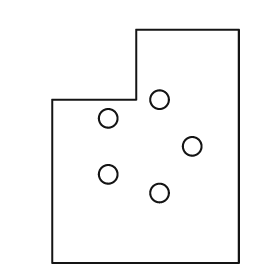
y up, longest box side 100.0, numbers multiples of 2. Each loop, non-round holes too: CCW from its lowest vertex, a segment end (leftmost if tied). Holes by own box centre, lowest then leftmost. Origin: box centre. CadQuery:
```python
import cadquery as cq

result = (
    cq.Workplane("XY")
    .moveTo(-40.0, -50.0)
    .lineTo(40.0, -50.0)
    .lineTo(40.0, 50.0)
    .lineTo(-4.0, 50.0)
    .lineTo(-4.0, 20.0)
    .lineTo(-40.0, 20.0)
    .close()
    .moveTo(6.0, -20.0)
    .circle(4.0)
    .moveTo(-16.0, -12.0)
    .circle(4.0)
    .moveTo(20.0, 0.0)
    .circle(4.0)
    .moveTo(-16.0, 12.0)
    .circle(4.0)
    .moveTo(6.0, 20.0)
    .circle(4.0)
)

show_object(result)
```